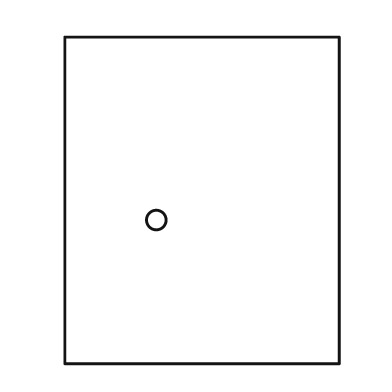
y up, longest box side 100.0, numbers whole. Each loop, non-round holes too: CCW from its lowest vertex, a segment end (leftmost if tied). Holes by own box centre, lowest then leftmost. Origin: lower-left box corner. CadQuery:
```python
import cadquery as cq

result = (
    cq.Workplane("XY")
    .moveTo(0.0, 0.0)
    .lineTo(84.0, 0.0)
    .lineTo(84.0, 100.0)
    .lineTo(0.0, 100.0)
    .close()
    .moveTo(28.0, 44.0)
    .circle(3.0)
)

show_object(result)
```